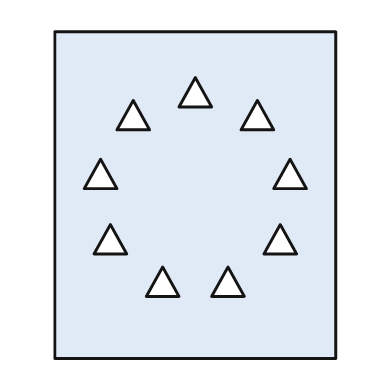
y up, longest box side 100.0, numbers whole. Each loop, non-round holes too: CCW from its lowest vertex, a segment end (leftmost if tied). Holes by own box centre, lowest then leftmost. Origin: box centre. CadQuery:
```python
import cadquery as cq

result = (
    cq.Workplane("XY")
    .moveTo(-43.0, -50.0)
    .lineTo(43.0, -50.0)
    .lineTo(43.0, 50.0)
    .lineTo(-43.0, 50.0)
    .close()
    .moveTo(-15.0, -31.0)
    .lineTo(-5.0, -31.0)
    .lineTo(-10.0, -22.0)
    .close()
    .moveTo(5.0, -31.0)
    .lineTo(15.0, -31.0)
    .lineTo(10.0, -22.0)
    .close()
    .moveTo(-31.0, -18.0)
    .lineTo(-21.0, -18.0)
    .lineTo(-26.0, -9.0)
    .close()
    .moveTo(21.0, -18.0)
    .lineTo(31.0, -18.0)
    .lineTo(26.0, -9.0)
    .close()
    .moveTo(-34.0, 2.0)
    .lineTo(-24.0, 2.0)
    .lineTo(-29.0, 11.0)
    .close()
    .moveTo(24.0, 2.0)
    .lineTo(34.0, 2.0)
    .lineTo(29.0, 11.0)
    .close()
    .moveTo(-24.0, 20.0)
    .lineTo(-14.0, 20.0)
    .lineTo(-19.0, 29.0)
    .close()
    .moveTo(14.0, 20.0)
    .lineTo(24.0, 20.0)
    .lineTo(19.0, 29.0)
    .close()
    .moveTo(-5.0, 27.0)
    .lineTo(5.0, 27.0)
    .lineTo(0.0, 36.0)
    .close()
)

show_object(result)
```